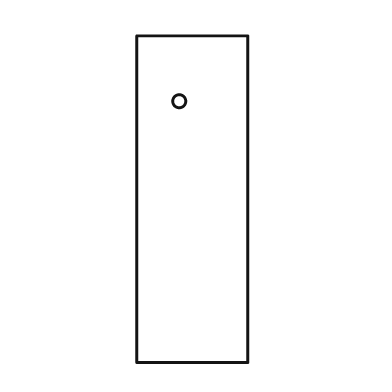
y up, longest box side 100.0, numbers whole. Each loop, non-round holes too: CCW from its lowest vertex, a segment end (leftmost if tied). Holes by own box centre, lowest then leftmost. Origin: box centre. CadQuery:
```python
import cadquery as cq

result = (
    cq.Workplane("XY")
    .moveTo(-17.0, -50.0)
    .lineTo(17.0, -50.0)
    .lineTo(17.0, 50.0)
    .lineTo(-17.0, 50.0)
    .close()
    .moveTo(-4.0, 30.0)
    .circle(2.0)
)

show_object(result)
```